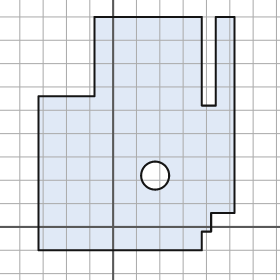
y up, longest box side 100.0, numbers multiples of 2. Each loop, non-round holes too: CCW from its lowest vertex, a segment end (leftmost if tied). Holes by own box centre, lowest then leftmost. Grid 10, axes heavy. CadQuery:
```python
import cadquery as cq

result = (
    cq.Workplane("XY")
    .moveTo(-32.0, -10.0)
    .lineTo(38.0, -10.0)
    .lineTo(38.0, -2.0)
    .lineTo(42.0, -2.0)
    .lineTo(42.0, 6.0)
    .lineTo(52.0, 6.0)
    .lineTo(52.0, 90.0)
    .lineTo(44.0, 90.0)
    .lineTo(44.0, 52.0)
    .lineTo(38.0, 52.0)
    .lineTo(38.0, 90.0)
    .lineTo(-8.0, 90.0)
    .lineTo(-8.0, 56.0)
    .lineTo(-32.0, 56.0)
    .close()
    .moveTo(18.0, 22.0)
    .circle(6.0)
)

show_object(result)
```